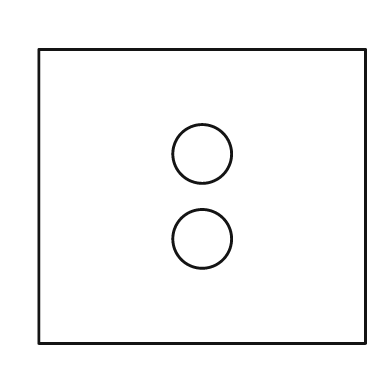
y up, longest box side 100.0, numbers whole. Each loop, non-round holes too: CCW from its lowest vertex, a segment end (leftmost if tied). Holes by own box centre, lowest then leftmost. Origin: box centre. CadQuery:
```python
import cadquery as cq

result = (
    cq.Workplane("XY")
    .moveTo(-50.0, -45.0)
    .lineTo(50.0, -45.0)
    .lineTo(50.0, 45.0)
    .lineTo(-50.0, 45.0)
    .close()
    .moveTo(0.0, -13.0)
    .circle(9.0)
    .moveTo(0.0, 13.0)
    .circle(9.0)
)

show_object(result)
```